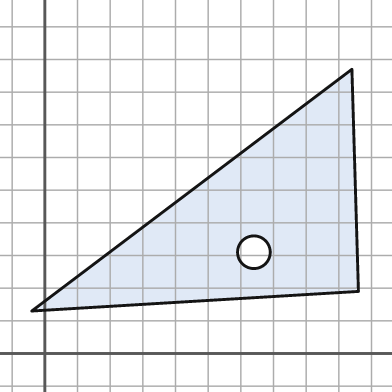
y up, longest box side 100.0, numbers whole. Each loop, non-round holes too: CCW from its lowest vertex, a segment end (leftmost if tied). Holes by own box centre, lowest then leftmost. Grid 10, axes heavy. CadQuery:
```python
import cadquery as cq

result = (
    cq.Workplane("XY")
    .moveTo(-4.0, 13.0)
    .lineTo(96.0, 19.0)
    .lineTo(94.0, 87.0)
    .close()
    .moveTo(64.0, 31.0)
    .circle(5.0)
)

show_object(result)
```